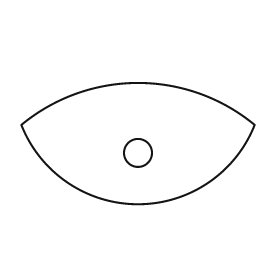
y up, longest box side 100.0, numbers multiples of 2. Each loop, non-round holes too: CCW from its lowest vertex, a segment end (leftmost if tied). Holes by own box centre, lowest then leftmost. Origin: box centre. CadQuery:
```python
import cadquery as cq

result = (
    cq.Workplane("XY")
    .moveTo(-50.0, 8.0)
    .threePointArc((0.0, -26.0), (50.0, 8.0))
    .threePointArc((0.0, 26.0), (-50.0, 8.0))
    .close()
    .moveTo(0.0, -4.0)
    .circle(6.0)
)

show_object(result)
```